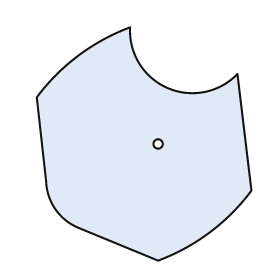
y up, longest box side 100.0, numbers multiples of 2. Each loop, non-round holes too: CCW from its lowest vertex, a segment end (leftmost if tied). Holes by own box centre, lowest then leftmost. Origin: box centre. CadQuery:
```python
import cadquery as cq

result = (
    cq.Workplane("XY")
    .moveTo(6.0, -50.0)
    .threePointArc((28.0, -38.0), (46.0, -20.0))
    .lineTo(40.0, 30.0)
    .threePointArc((10.0, 24.0), (-6.0, 50.0))
    .threePointArc((-28.0, 38.0), (-46.0, 20.0))
    .lineTo(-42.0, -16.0)
    .threePointArc((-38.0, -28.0), (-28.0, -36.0))
    .close()
    .moveTo(6.0, 0.0)
    .circle(2.0)
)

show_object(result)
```